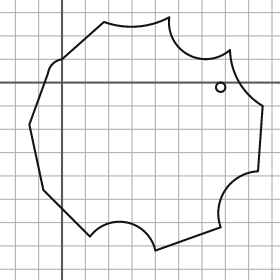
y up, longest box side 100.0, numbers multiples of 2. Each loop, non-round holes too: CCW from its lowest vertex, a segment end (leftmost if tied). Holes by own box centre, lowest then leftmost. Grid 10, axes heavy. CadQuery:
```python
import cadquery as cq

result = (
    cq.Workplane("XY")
    .moveTo(40.0, -72.0)
    .lineTo(68.0, -62.0)
    .threePointArc((70.0, -46.0), (84.0, -38.0))
    .lineTo(86.0, -10.0)
    .threePointArc((76.0, 0.0), (72.0, 14.0))
    .threePointArc((54.0, 12.0), (46.0, 28.0))
    .threePointArc((32.0, 24.0), (18.0, 26.0))
    .lineTo(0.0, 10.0)
    .threePointArc((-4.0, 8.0), (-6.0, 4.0))
    .lineTo(-14.0, -18.0)
    .lineTo(-8.0, -46.0)
    .lineTo(12.0, -66.0)
    .threePointArc((28.0, -60.0), (40.0, -72.0))
    .close()
    .moveTo(68.0, -2.0)
    .circle(2.0)
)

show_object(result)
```